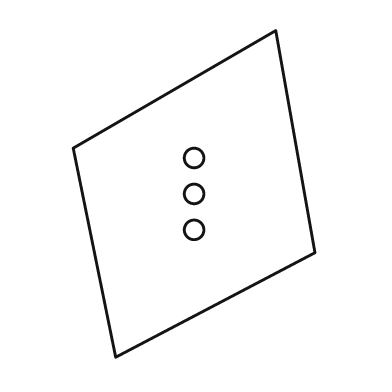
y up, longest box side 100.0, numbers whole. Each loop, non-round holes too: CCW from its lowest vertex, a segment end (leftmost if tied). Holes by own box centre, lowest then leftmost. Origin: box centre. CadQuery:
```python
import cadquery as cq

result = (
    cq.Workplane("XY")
    .moveTo(-24.0, -50.0)
    .lineTo(37.0, -18.0)
    .lineTo(25.0, 50.0)
    .lineTo(-37.0, 14.0)
    .close()
    .moveTo(0.0, -11.0)
    .circle(3.0)
    .moveTo(0.0, 0.0)
    .circle(3.0)
    .moveTo(0.0, 11.0)
    .circle(3.0)
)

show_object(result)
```